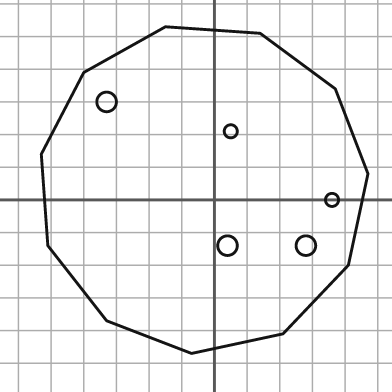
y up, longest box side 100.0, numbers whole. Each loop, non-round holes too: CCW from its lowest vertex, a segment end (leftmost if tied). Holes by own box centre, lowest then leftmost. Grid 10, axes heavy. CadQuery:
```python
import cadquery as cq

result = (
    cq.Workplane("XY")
    .moveTo(-7.0, -47.0)
    .lineTo(21.0, -41.0)
    .lineTo(41.0, -20.0)
    .lineTo(47.0, 8.0)
    .lineTo(37.0, 34.0)
    .lineTo(14.0, 51.0)
    .lineTo(-15.0, 53.0)
    .lineTo(-40.0, 39.0)
    .lineTo(-53.0, 14.0)
    .lineTo(-51.0, -14.0)
    .lineTo(-33.0, -37.0)
    .close()
    .moveTo(4.0, -14.0)
    .circle(3.0)
    .moveTo(28.0, -14.0)
    .circle(3.0)
    .moveTo(36.0, 0.0)
    .circle(2.0)
    .moveTo(5.0, 21.0)
    .circle(2.0)
    .moveTo(-33.0, 30.0)
    .circle(3.0)
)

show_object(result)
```